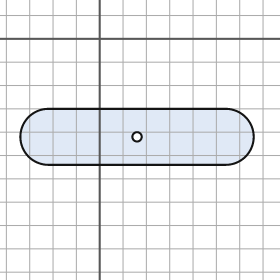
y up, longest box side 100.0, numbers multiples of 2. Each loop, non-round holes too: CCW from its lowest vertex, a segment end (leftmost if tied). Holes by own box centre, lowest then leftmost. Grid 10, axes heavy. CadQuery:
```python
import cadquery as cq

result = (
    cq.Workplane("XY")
    .moveTo(-22.0, -54.0)
    .lineTo(54.0, -54.0)
    .threePointArc((66.0, -42.0), (54.0, -30.0))
    .lineTo(-22.0, -30.0)
    .threePointArc((-34.0, -42.0), (-22.0, -54.0))
    .close()
    .moveTo(16.0, -42.0)
    .circle(2.0)
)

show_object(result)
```